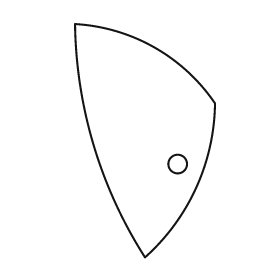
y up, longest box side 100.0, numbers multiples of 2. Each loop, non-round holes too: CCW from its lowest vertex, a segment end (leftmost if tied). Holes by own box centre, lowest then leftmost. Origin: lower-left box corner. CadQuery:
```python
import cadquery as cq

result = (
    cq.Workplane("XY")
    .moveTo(30.0, 0.0)
    .threePointArc((52.0, 30.0), (60.0, 66.0))
    .threePointArc((34.0, 90.0), (0.0, 100.0))
    .threePointArc((8.0, 48.0), (30.0, 0.0))
    .close()
    .moveTo(44.0, 40.0)
    .circle(4.0)
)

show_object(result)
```